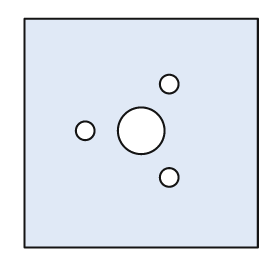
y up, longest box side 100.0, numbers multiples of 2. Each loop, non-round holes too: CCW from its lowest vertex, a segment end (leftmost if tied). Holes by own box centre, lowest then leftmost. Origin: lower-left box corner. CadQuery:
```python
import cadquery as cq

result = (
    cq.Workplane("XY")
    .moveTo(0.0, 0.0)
    .lineTo(100.0, 0.0)
    .lineTo(100.0, 98.0)
    .lineTo(0.0, 98.0)
    .close()
    .moveTo(62.0, 30.0)
    .circle(4.0)
    .moveTo(26.0, 50.0)
    .circle(4.0)
    .moveTo(50.0, 50.0)
    .circle(10.0)
    .moveTo(62.0, 70.0)
    .circle(4.0)
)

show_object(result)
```